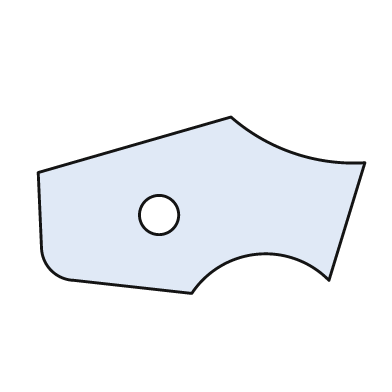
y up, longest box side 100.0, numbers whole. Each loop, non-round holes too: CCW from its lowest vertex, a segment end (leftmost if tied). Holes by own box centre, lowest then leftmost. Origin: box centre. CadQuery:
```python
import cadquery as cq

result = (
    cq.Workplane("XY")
    .moveTo(-3.0, -27.0)
    .threePointArc((17.0, -15.0), (39.0, -23.0))
    .lineTo(50.0, 13.0)
    .threePointArc((28.0, 16.0), (9.0, 27.0))
    .lineTo(-50.0, 10.0)
    .lineTo(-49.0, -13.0)
    .threePointArc((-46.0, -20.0), (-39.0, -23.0))
    .close()
    .moveTo(-13.0, -3.0)
    .circle(6.0)
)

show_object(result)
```